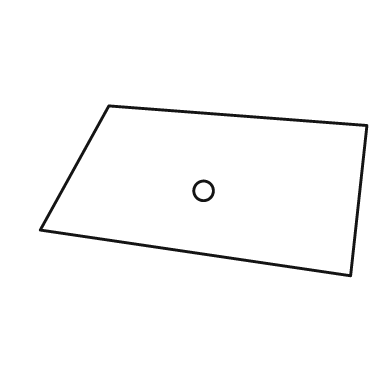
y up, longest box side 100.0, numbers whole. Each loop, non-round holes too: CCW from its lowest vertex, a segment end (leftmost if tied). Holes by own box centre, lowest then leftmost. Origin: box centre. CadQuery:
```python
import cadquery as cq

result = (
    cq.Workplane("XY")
    .moveTo(45.0, -26.0)
    .lineTo(50.0, 20.0)
    .lineTo(-29.0, 26.0)
    .lineTo(-50.0, -12.0)
    .close()
    .moveTo(0.0, 0.0)
    .circle(3.0)
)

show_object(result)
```